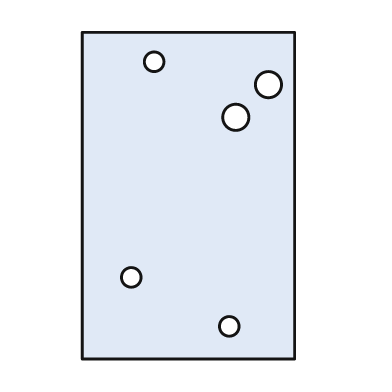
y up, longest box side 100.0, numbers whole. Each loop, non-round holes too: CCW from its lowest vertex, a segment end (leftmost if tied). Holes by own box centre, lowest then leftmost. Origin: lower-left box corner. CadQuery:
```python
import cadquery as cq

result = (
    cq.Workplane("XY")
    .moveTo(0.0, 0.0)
    .lineTo(65.0, 0.0)
    .lineTo(65.0, 100.0)
    .lineTo(0.0, 100.0)
    .close()
    .moveTo(45.0, 10.0)
    .circle(3.0)
    .moveTo(15.0, 25.0)
    .circle(3.0)
    .moveTo(47.0, 74.0)
    .circle(4.0)
    .moveTo(57.0, 84.0)
    .circle(4.0)
    .moveTo(22.0, 91.0)
    .circle(3.0)
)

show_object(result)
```